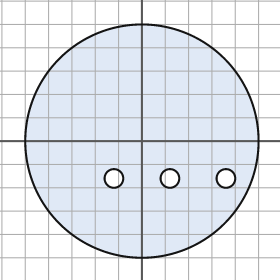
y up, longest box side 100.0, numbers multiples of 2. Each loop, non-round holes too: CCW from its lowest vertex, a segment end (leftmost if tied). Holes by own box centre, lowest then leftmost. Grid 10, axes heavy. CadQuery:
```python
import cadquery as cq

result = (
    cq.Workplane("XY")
    .moveTo(0.0, 0.0)
    .circle(50.0)
    .moveTo(-12.0, -16.0)
    .circle(4.0)
    .moveTo(12.0, -16.0)
    .circle(4.0)
    .moveTo(36.0, -16.0)
    .circle(4.0)
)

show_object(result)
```